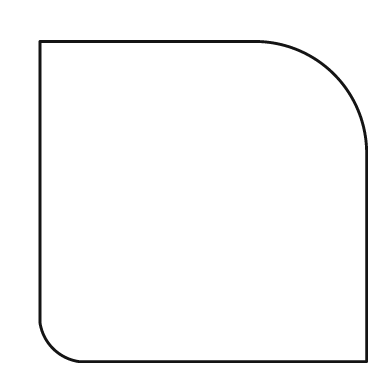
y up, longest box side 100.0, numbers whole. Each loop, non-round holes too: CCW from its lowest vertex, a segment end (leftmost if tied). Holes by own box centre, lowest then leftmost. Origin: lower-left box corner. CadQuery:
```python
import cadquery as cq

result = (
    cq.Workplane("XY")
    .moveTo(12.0, 0.0)
    .lineTo(100.0, 0.0)
    .lineTo(100.0, 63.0)
    .threePointArc((90.0, 88.0), (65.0, 98.0))
    .lineTo(0.0, 98.0)
    .lineTo(0.0, 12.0)
    .threePointArc((4.0, 4.0), (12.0, 0.0))
    .close()
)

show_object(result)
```